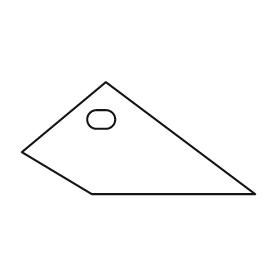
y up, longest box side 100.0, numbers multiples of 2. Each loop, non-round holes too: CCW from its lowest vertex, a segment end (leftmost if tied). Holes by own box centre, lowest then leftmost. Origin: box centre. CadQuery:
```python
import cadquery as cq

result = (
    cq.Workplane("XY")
    .moveTo(-20.0, -24.0)
    .lineTo(50.0, -24.0)
    .lineTo(-14.0, 24.0)
    .lineTo(-50.0, -6.0)
    .close()
    .moveTo(-18.0, 4.0)
    .lineTo(-14.0, 4.0)
    .threePointArc((-10.0, 8.0), (-14.0, 12.0))
    .lineTo(-18.0, 12.0)
    .threePointArc((-22.0, 8.0), (-18.0, 4.0))
    .close()
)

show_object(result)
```